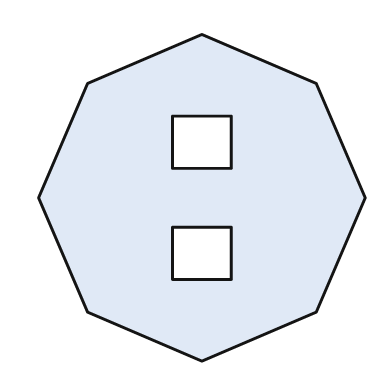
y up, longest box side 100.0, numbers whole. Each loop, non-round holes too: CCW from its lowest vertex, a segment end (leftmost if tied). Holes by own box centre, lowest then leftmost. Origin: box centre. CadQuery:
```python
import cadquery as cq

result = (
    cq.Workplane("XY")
    .moveTo(0.0, -50.0)
    .lineTo(35.0, -35.0)
    .lineTo(50.0, 0.0)
    .lineTo(35.0, 35.0)
    .lineTo(0.0, 50.0)
    .lineTo(-35.0, 35.0)
    .lineTo(-50.0, 0.0)
    .lineTo(-35.0, -35.0)
    .close()
    .moveTo(-9.0, -25.0)
    .lineTo(9.0, -25.0)
    .lineTo(9.0, -9.0)
    .lineTo(-9.0, -9.0)
    .close()
    .moveTo(-9.0, 9.0)
    .lineTo(9.0, 9.0)
    .lineTo(9.0, 25.0)
    .lineTo(-9.0, 25.0)
    .close()
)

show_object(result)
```